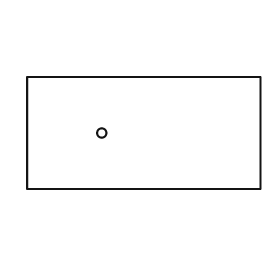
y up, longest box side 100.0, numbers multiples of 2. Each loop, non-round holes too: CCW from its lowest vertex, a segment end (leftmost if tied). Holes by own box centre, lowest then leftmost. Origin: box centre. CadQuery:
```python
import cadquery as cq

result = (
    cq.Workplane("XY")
    .moveTo(-50.0, -24.0)
    .lineTo(50.0, -24.0)
    .lineTo(50.0, 24.0)
    .lineTo(-50.0, 24.0)
    .close()
    .moveTo(-18.0, 0.0)
    .circle(2.0)
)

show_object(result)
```